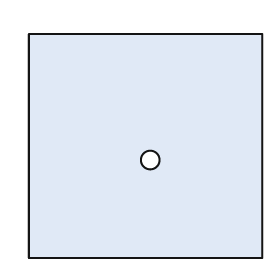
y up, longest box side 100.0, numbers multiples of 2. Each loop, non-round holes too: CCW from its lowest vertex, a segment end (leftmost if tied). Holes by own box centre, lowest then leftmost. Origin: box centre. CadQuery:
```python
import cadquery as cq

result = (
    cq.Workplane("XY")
    .moveTo(-50.0, -48.0)
    .lineTo(50.0, -48.0)
    .lineTo(50.0, 48.0)
    .lineTo(-50.0, 48.0)
    .close()
    .moveTo(2.0, -6.0)
    .circle(4.0)
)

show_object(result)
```